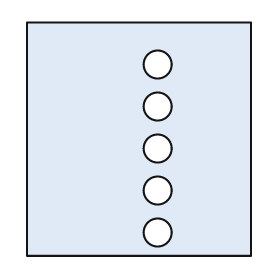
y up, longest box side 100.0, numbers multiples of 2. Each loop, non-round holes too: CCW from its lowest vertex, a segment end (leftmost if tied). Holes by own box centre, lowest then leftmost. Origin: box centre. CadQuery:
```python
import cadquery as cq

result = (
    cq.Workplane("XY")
    .moveTo(-48.0, -50.0)
    .lineTo(48.0, -50.0)
    .lineTo(48.0, 50.0)
    .lineTo(-48.0, 50.0)
    .close()
    .moveTo(8.0, -40.0)
    .circle(6.0)
    .moveTo(8.0, -22.0)
    .circle(6.0)
    .moveTo(8.0, -4.0)
    .circle(6.0)
    .moveTo(8.0, 14.0)
    .circle(6.0)
    .moveTo(8.0, 32.0)
    .circle(6.0)
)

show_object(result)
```